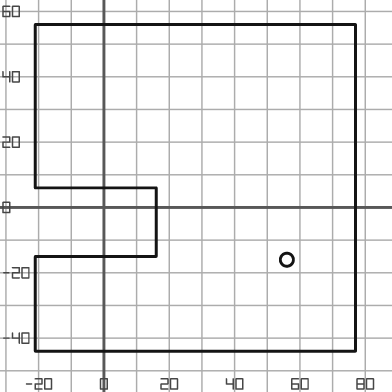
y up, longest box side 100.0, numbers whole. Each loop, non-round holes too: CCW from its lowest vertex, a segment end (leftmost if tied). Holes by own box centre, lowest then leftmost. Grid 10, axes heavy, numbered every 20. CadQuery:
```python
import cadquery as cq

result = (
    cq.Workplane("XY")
    .moveTo(-21.0, -44.0)
    .lineTo(77.0, -44.0)
    .lineTo(77.0, 56.0)
    .lineTo(-21.0, 56.0)
    .lineTo(-21.0, 6.0)
    .lineTo(16.0, 6.0)
    .lineTo(16.0, -15.0)
    .lineTo(-21.0, -15.0)
    .close()
    .moveTo(56.0, -16.0)
    .circle(2.0)
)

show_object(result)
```